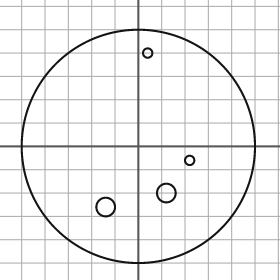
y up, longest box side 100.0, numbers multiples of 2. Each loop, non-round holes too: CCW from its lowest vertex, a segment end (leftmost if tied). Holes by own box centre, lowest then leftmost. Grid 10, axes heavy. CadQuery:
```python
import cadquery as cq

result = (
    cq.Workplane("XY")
    .moveTo(0.0, 0.0)
    .circle(50.0)
    .moveTo(-14.0, -26.0)
    .circle(4.0)
    .moveTo(12.0, -20.0)
    .circle(4.0)
    .moveTo(22.0, -6.0)
    .circle(2.0)
    .moveTo(4.0, 40.0)
    .circle(2.0)
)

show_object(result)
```